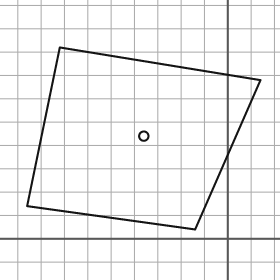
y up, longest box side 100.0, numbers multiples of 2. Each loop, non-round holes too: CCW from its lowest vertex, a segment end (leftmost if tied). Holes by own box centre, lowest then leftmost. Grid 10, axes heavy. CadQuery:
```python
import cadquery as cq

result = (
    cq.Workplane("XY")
    .moveTo(-14.0, 4.0)
    .lineTo(14.0, 68.0)
    .lineTo(-72.0, 82.0)
    .lineTo(-86.0, 14.0)
    .close()
    .moveTo(-36.0, 44.0)
    .circle(2.0)
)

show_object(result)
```